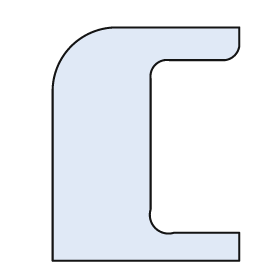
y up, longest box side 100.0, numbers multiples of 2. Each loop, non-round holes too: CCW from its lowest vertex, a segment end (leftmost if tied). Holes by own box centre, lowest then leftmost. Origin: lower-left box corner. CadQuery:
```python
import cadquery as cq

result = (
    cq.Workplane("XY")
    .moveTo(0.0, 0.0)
    .lineTo(80.0, 0.0)
    .lineTo(80.0, 12.0)
    .lineTo(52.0, 12.0)
    .threePointArc((44.0, 14.0), (42.0, 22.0))
    .lineTo(42.0, 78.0)
    .threePointArc((44.0, 84.0), (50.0, 86.0))
    .lineTo(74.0, 86.0)
    .threePointArc((78.0, 88.0), (80.0, 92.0))
    .lineTo(80.0, 100.0)
    .lineTo(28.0, 100.0)
    .threePointArc((8.0, 92.0), (0.0, 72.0))
    .close()
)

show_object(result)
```